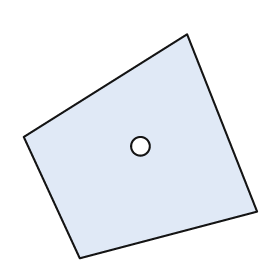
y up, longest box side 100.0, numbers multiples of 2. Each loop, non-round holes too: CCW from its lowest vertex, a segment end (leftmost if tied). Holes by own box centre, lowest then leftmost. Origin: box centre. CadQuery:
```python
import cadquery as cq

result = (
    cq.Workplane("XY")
    .moveTo(-26.0, -48.0)
    .lineTo(50.0, -28.0)
    .lineTo(20.0, 48.0)
    .lineTo(-50.0, 4.0)
    .close()
    .moveTo(0.0, 0.0)
    .circle(4.0)
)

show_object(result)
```